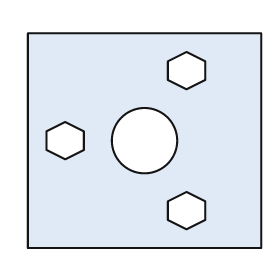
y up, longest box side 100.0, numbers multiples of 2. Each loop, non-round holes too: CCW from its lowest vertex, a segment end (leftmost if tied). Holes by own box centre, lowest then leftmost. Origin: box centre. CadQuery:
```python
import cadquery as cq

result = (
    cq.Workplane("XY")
    .moveTo(-50.0, -46.0)
    .lineTo(50.0, -46.0)
    .lineTo(50.0, 46.0)
    .lineTo(-50.0, 46.0)
    .close()
    .moveTo(18.0, -38.0)
    .lineTo(26.0, -34.0)
    .lineTo(26.0, -26.0)
    .lineTo(18.0, -22.0)
    .lineTo(10.0, -26.0)
    .lineTo(10.0, -34.0)
    .close()
    .moveTo(-34.0, -8.0)
    .lineTo(-26.0, -4.0)
    .lineTo(-26.0, 4.0)
    .lineTo(-34.0, 8.0)
    .lineTo(-42.0, 4.0)
    .lineTo(-42.0, -4.0)
    .close()
    .moveTo(0.0, 0.0)
    .circle(14.0)
    .moveTo(18.0, 22.0)
    .lineTo(26.0, 26.0)
    .lineTo(26.0, 34.0)
    .lineTo(18.0, 38.0)
    .lineTo(10.0, 34.0)
    .lineTo(10.0, 26.0)
    .close()
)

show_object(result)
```